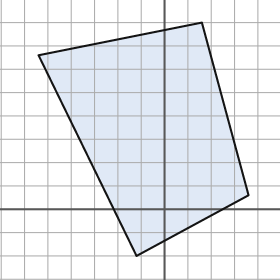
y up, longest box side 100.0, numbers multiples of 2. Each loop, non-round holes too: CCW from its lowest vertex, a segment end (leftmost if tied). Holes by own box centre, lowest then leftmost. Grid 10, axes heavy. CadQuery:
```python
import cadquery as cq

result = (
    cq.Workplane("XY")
    .moveTo(-12.0, -20.0)
    .lineTo(36.0, 6.0)
    .lineTo(16.0, 80.0)
    .lineTo(-54.0, 66.0)
    .close()
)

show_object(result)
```